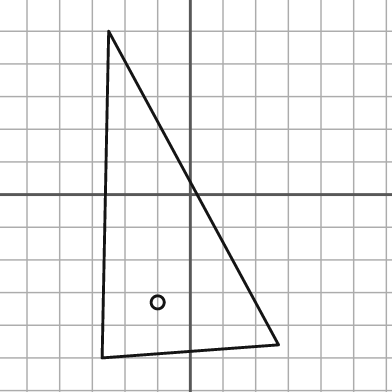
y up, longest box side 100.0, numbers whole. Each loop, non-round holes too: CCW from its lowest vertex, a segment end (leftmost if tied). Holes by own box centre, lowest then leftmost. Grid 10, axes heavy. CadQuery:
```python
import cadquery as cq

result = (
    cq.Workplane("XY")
    .moveTo(-27.0, -50.0)
    .lineTo(27.0, -46.0)
    .lineTo(-25.0, 50.0)
    .close()
    .moveTo(-10.0, -33.0)
    .circle(2.0)
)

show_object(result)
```